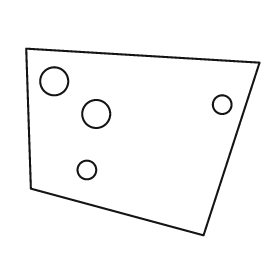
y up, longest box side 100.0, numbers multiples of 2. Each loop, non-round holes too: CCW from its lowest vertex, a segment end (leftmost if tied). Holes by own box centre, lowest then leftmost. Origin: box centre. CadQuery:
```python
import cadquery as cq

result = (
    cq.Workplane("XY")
    .moveTo(26.0, -40.0)
    .lineTo(50.0, 34.0)
    .lineTo(-50.0, 40.0)
    .lineTo(-48.0, -20.0)
    .close()
    .moveTo(-24.0, -12.0)
    .circle(4.0)
    .moveTo(-20.0, 12.0)
    .circle(6.0)
    .moveTo(34.0, 16.0)
    .circle(4.0)
    .moveTo(-38.0, 26.0)
    .circle(6.0)
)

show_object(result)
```